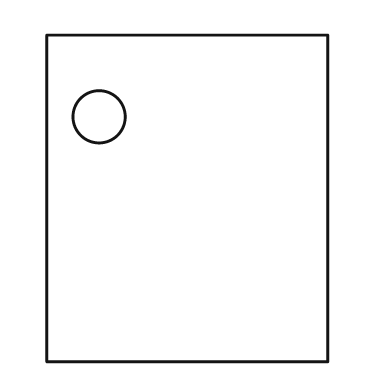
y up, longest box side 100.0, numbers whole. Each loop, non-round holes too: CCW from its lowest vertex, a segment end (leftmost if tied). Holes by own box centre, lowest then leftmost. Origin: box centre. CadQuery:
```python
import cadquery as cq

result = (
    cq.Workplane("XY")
    .moveTo(-43.0, -50.0)
    .lineTo(43.0, -50.0)
    .lineTo(43.0, 50.0)
    .lineTo(-43.0, 50.0)
    .close()
    .moveTo(-27.0, 25.0)
    .circle(8.0)
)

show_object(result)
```